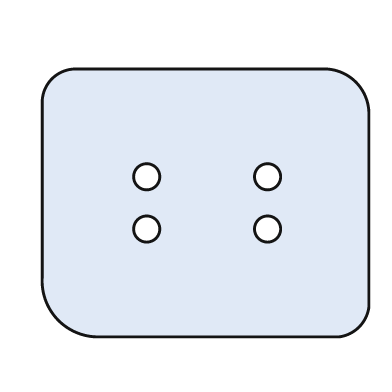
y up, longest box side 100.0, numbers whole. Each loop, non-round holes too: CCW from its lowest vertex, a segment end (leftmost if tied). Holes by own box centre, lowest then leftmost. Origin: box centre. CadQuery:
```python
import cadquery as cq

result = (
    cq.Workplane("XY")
    .moveTo(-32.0, -41.0)
    .lineTo(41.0, -41.0)
    .threePointArc((47.0, -38.0), (50.0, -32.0))
    .lineTo(50.0, 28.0)
    .threePointArc((46.0, 37.0), (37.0, 41.0))
    .lineTo(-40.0, 41.0)
    .threePointArc((-47.0, 38.0), (-50.0, 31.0))
    .lineTo(-50.0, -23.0)
    .threePointArc((-45.0, -36.0), (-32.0, -41.0))
    .close()
    .moveTo(-18.0, -8.0)
    .circle(4.0)
    .moveTo(19.0, -8.0)
    .circle(4.0)
    .moveTo(-18.0, 8.0)
    .circle(4.0)
    .moveTo(19.0, 8.0)
    .circle(4.0)
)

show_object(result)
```